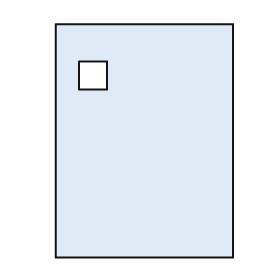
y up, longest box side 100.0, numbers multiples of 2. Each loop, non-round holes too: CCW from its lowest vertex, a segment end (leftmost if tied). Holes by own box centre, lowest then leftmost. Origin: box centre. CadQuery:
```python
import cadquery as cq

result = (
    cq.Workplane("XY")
    .moveTo(-38.0, -50.0)
    .lineTo(38.0, -50.0)
    .lineTo(38.0, 50.0)
    .lineTo(-38.0, 50.0)
    .close()
    .moveTo(-28.0, 22.0)
    .lineTo(-16.0, 22.0)
    .lineTo(-16.0, 34.0)
    .lineTo(-28.0, 34.0)
    .close()
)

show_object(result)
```